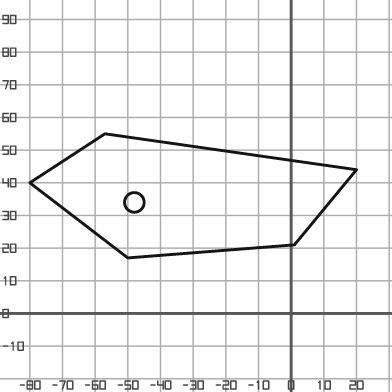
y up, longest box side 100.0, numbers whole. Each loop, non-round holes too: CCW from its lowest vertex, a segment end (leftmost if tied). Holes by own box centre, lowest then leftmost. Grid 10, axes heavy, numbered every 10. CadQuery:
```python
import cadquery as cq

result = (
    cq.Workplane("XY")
    .moveTo(-50.0, 17.0)
    .lineTo(1.0, 21.0)
    .lineTo(20.0, 44.0)
    .lineTo(-57.0, 55.0)
    .lineTo(-80.0, 40.0)
    .close()
    .moveTo(-48.0, 34.0)
    .circle(3.0)
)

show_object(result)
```